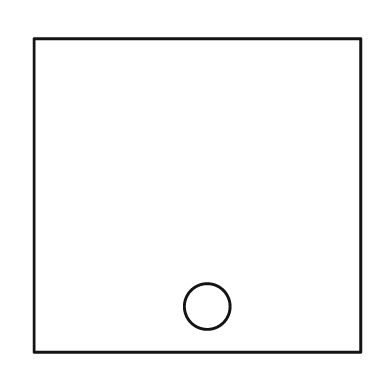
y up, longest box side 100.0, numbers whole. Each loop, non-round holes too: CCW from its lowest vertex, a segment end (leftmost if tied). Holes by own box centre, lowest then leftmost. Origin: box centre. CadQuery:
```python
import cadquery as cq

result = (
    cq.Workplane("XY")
    .moveTo(-50.0, -48.0)
    .lineTo(50.0, -48.0)
    .lineTo(50.0, 48.0)
    .lineTo(-50.0, 48.0)
    .close()
    .moveTo(3.0, -34.0)
    .circle(7.0)
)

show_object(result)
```